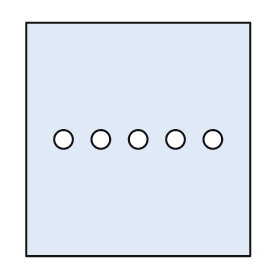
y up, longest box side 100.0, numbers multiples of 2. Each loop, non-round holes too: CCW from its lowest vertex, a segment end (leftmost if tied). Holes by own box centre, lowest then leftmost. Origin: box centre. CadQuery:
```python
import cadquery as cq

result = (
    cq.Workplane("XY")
    .moveTo(-48.0, -50.0)
    .lineTo(48.0, -50.0)
    .lineTo(48.0, 50.0)
    .lineTo(-48.0, 50.0)
    .close()
    .moveTo(-32.0, 0.0)
    .circle(4.0)
    .moveTo(-16.0, 0.0)
    .circle(4.0)
    .moveTo(0.0, 0.0)
    .circle(4.0)
    .moveTo(16.0, 0.0)
    .circle(4.0)
    .moveTo(32.0, 0.0)
    .circle(4.0)
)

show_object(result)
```